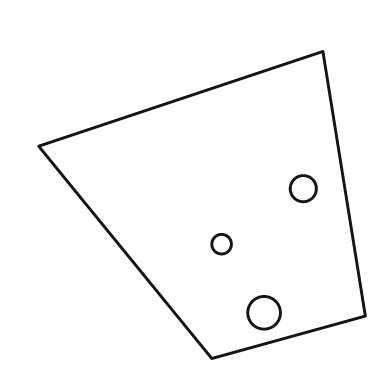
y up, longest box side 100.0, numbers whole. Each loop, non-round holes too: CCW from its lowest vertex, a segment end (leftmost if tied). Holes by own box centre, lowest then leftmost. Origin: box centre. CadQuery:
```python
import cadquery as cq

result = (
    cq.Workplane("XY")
    .moveTo(3.0, -47.0)
    .lineTo(50.0, -34.0)
    .lineTo(37.0, 47.0)
    .lineTo(-50.0, 18.0)
    .close()
    .moveTo(19.0, -33.0)
    .circle(5.0)
    .moveTo(6.0, -12.0)
    .circle(3.0)
    .moveTo(31.0, 5.0)
    .circle(4.0)
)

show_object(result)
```